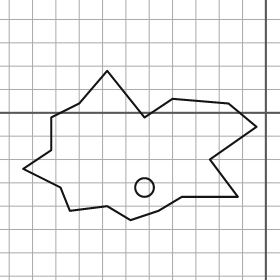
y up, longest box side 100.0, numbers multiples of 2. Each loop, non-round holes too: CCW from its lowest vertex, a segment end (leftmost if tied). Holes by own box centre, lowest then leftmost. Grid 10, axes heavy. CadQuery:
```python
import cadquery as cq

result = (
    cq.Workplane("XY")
    .moveTo(-58.0, -46.0)
    .lineTo(-46.0, -42.0)
    .lineTo(-36.0, -36.0)
    .lineTo(-12.0, -36.0)
    .lineTo(-24.0, -20.0)
    .lineTo(-4.0, -6.0)
    .lineTo(-16.0, 4.0)
    .lineTo(-40.0, 6.0)
    .lineTo(-52.0, -2.0)
    .lineTo(-68.0, 18.0)
    .lineTo(-80.0, 4.0)
    .lineTo(-92.0, -2.0)
    .lineTo(-92.0, -16.0)
    .lineTo(-104.0, -24.0)
    .lineTo(-88.0, -32.0)
    .lineTo(-84.0, -42.0)
    .lineTo(-68.0, -40.0)
    .close()
    .moveTo(-52.0, -32.0)
    .circle(4.0)
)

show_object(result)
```